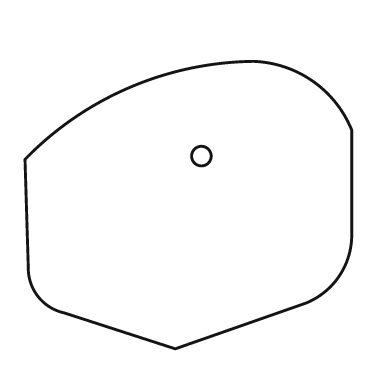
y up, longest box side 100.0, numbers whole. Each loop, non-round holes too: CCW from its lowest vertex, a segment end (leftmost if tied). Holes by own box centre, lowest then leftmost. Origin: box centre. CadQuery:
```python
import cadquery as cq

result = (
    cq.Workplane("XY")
    .moveTo(-4.0, -44.0)
    .lineTo(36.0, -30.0)
    .threePointArc((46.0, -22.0), (50.0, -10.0))
    .lineTo(50.0, 23.0)
    .threePointArc((38.0, 38.0), (20.0, 44.0))
    .threePointArc((-18.0, 36.0), (-50.0, 14.0))
    .lineTo(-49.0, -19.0)
    .threePointArc((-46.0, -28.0), (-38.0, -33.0))
    .close()
    .moveTo(4.0, 15.0)
    .circle(3.0)
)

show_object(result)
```